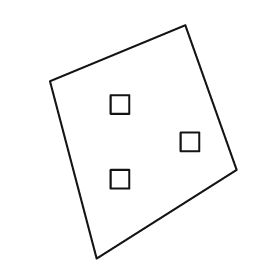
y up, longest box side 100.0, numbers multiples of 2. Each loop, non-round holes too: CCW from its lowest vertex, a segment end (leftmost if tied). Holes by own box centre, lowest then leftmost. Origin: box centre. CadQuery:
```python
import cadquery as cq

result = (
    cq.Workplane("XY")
    .moveTo(-20.0, -50.0)
    .lineTo(40.0, -12.0)
    .lineTo(18.0, 50.0)
    .lineTo(-40.0, 26.0)
    .close()
    .moveTo(-14.0, -20.0)
    .lineTo(-6.0, -20.0)
    .lineTo(-6.0, -12.0)
    .lineTo(-14.0, -12.0)
    .close()
    .moveTo(16.0, -4.0)
    .lineTo(24.0, -4.0)
    .lineTo(24.0, 4.0)
    .lineTo(16.0, 4.0)
    .close()
    .moveTo(-14.0, 12.0)
    .lineTo(-6.0, 12.0)
    .lineTo(-6.0, 20.0)
    .lineTo(-14.0, 20.0)
    .close()
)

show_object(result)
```